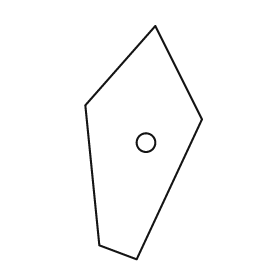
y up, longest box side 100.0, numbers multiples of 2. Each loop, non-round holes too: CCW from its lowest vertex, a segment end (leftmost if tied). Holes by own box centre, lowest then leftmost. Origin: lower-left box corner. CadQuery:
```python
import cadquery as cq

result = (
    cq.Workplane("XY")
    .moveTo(22.0, 0.0)
    .lineTo(50.0, 60.0)
    .lineTo(30.0, 100.0)
    .lineTo(0.0, 66.0)
    .lineTo(6.0, 6.0)
    .close()
    .moveTo(26.0, 50.0)
    .circle(4.0)
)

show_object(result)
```